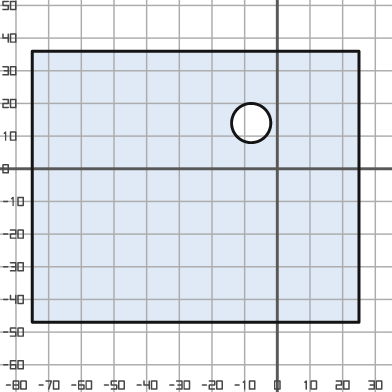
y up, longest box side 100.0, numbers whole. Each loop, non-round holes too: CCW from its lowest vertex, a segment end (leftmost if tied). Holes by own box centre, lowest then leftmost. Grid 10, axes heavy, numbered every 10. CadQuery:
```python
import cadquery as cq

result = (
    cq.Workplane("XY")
    .moveTo(-75.0, -47.0)
    .lineTo(25.0, -47.0)
    .lineTo(25.0, 36.0)
    .lineTo(-75.0, 36.0)
    .close()
    .moveTo(-8.0, 14.0)
    .circle(6.0)
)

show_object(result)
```